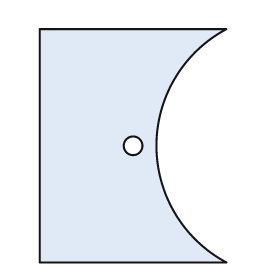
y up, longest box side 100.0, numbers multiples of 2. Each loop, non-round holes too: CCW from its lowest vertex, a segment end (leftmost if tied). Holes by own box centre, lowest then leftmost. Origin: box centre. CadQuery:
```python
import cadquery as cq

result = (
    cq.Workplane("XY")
    .moveTo(-40.0, -50.0)
    .lineTo(40.0, -50.0)
    .threePointArc((10.0, 0.0), (40.0, 50.0))
    .lineTo(-40.0, 50.0)
    .close()
    .moveTo(0.0, 0.0)
    .circle(4.0)
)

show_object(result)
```